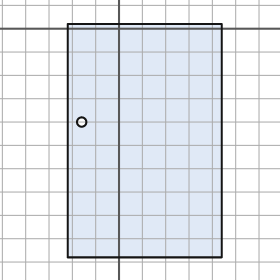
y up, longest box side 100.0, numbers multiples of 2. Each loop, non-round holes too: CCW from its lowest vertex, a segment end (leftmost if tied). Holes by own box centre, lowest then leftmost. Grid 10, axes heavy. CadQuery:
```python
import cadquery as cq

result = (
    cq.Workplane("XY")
    .moveTo(-22.0, -98.0)
    .lineTo(44.0, -98.0)
    .lineTo(44.0, 2.0)
    .lineTo(-22.0, 2.0)
    .close()
    .moveTo(-16.0, -40.0)
    .circle(2.0)
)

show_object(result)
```